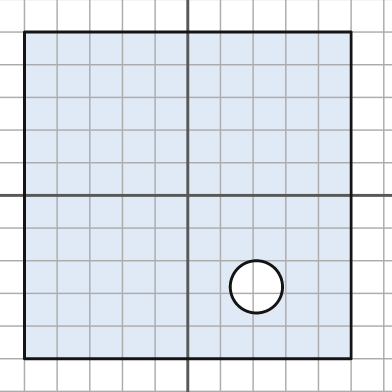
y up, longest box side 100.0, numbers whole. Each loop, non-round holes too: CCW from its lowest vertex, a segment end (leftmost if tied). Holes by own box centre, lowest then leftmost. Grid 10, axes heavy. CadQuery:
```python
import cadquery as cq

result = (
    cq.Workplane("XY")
    .moveTo(-50.0, -50.0)
    .lineTo(50.0, -50.0)
    .lineTo(50.0, 50.0)
    .lineTo(-50.0, 50.0)
    .close()
    .moveTo(21.0, -28.0)
    .circle(8.0)
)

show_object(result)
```